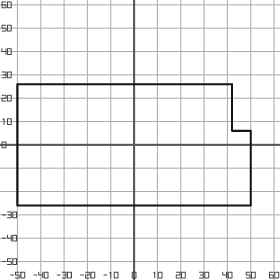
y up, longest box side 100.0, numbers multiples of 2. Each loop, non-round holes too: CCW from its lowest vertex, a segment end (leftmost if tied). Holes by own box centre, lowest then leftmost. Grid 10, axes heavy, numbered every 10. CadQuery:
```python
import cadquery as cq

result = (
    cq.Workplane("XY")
    .moveTo(-50.0, -26.0)
    .lineTo(50.0, -26.0)
    .lineTo(50.0, 6.0)
    .lineTo(42.0, 6.0)
    .lineTo(42.0, 26.0)
    .lineTo(-50.0, 26.0)
    .close()
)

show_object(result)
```